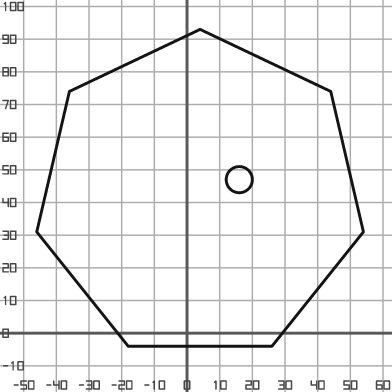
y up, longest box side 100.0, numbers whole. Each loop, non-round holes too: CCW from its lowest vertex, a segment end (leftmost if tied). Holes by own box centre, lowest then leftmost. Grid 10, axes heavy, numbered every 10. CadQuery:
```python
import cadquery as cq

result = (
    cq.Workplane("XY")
    .moveTo(-18.0, -4.0)
    .lineTo(26.0, -4.0)
    .lineTo(54.0, 31.0)
    .lineTo(44.0, 74.0)
    .lineTo(4.0, 93.0)
    .lineTo(-36.0, 74.0)
    .lineTo(-46.0, 31.0)
    .close()
    .moveTo(16.0, 47.0)
    .circle(4.0)
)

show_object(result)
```